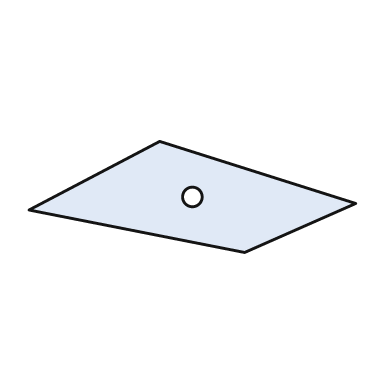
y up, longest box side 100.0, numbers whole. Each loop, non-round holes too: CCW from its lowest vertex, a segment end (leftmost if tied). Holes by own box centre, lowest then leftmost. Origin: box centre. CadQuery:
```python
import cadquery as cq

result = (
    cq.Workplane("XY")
    .moveTo(16.0, -17.0)
    .lineTo(50.0, -2.0)
    .lineTo(-10.0, 17.0)
    .lineTo(-50.0, -4.0)
    .close()
    .moveTo(0.0, 0.0)
    .circle(3.0)
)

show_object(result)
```